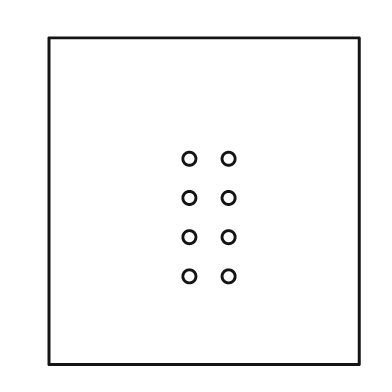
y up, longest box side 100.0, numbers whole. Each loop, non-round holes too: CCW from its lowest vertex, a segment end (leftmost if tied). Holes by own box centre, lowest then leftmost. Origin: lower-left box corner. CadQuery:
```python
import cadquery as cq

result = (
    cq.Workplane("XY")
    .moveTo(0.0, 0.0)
    .lineTo(95.0, 0.0)
    .lineTo(95.0, 100.0)
    .lineTo(0.0, 100.0)
    .close()
    .moveTo(43.0, 27.0)
    .circle(2.0)
    .moveTo(55.0, 27.0)
    .circle(2.0)
    .moveTo(43.0, 39.0)
    .circle(2.0)
    .moveTo(55.0, 39.0)
    .circle(2.0)
    .moveTo(43.0, 51.0)
    .circle(2.0)
    .moveTo(55.0, 51.0)
    .circle(2.0)
    .moveTo(43.0, 63.0)
    .circle(2.0)
    .moveTo(55.0, 63.0)
    .circle(2.0)
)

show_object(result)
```